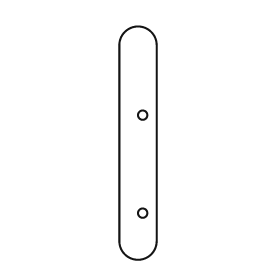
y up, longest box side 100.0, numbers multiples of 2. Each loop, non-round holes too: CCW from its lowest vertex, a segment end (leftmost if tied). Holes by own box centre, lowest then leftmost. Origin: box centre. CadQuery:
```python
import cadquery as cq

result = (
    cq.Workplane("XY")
    .moveTo(-8.0, -42.0)
    .threePointArc((0.0, -50.0), (8.0, -42.0))
    .lineTo(8.0, 42.0)
    .threePointArc((0.0, 50.0), (-8.0, 42.0))
    .close()
    .moveTo(2.0, -30.0)
    .circle(2.0)
    .moveTo(2.0, 12.0)
    .circle(2.0)
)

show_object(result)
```